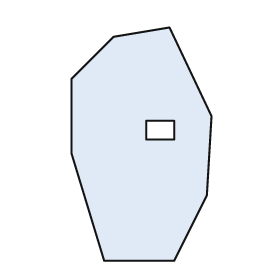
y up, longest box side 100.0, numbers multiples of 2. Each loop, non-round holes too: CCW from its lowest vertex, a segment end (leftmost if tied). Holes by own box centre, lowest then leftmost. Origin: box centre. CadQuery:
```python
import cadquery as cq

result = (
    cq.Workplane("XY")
    .moveTo(-16.0, -50.0)
    .lineTo(14.0, -50.0)
    .lineTo(28.0, -22.0)
    .lineTo(30.0, 12.0)
    .lineTo(12.0, 50.0)
    .lineTo(-12.0, 46.0)
    .lineTo(-30.0, 28.0)
    .lineTo(-30.0, -4.0)
    .close()
    .moveTo(2.0, 2.0)
    .lineTo(14.0, 2.0)
    .lineTo(14.0, 10.0)
    .lineTo(2.0, 10.0)
    .close()
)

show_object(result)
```